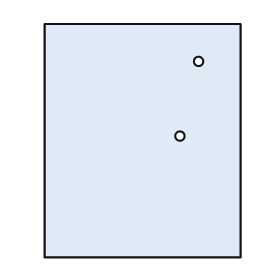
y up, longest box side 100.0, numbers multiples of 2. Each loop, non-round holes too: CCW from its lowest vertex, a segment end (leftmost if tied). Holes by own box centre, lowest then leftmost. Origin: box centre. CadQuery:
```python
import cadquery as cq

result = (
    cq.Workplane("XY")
    .moveTo(-42.0, -50.0)
    .lineTo(42.0, -50.0)
    .lineTo(42.0, 50.0)
    .lineTo(-42.0, 50.0)
    .close()
    .moveTo(16.0, 2.0)
    .circle(2.0)
    .moveTo(24.0, 34.0)
    .circle(2.0)
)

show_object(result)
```